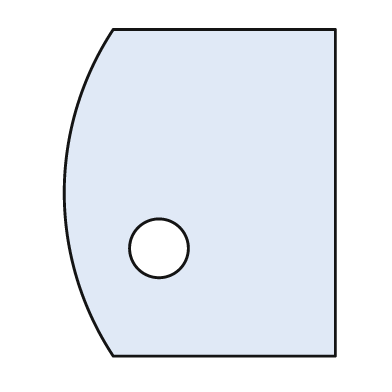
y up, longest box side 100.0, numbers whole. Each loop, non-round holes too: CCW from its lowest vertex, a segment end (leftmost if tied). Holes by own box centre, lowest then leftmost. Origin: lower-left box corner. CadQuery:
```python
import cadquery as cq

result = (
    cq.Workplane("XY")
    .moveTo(15.0, 0.0)
    .lineTo(83.0, 0.0)
    .lineTo(83.0, 100.0)
    .lineTo(15.0, 100.0)
    .threePointArc((0.0, 50.0), (15.0, 0.0))
    .close()
    .moveTo(29.0, 33.0)
    .circle(9.0)
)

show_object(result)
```